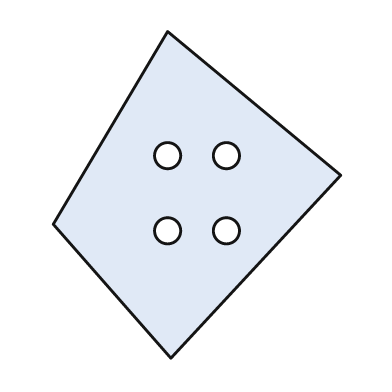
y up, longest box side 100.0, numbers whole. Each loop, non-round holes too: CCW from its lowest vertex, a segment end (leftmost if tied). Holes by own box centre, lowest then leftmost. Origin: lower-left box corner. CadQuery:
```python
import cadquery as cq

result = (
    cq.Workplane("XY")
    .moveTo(36.0, 0.0)
    .lineTo(88.0, 56.0)
    .lineTo(35.0, 100.0)
    .lineTo(0.0, 41.0)
    .close()
    .moveTo(35.0, 39.0)
    .circle(4.0)
    .moveTo(53.0, 39.0)
    .circle(4.0)
    .moveTo(35.0, 62.0)
    .circle(4.0)
    .moveTo(53.0, 62.0)
    .circle(4.0)
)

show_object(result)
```